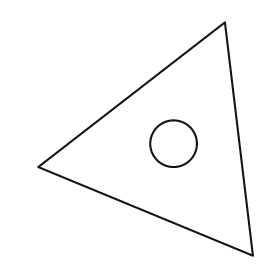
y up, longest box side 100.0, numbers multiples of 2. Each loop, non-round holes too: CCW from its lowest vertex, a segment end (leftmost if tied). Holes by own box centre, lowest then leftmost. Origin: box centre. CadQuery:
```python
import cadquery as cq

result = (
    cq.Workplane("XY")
    .moveTo(46.0, -50.0)
    .lineTo(34.0, 50.0)
    .lineTo(-46.0, -12.0)
    .close()
    .moveTo(12.0, -2.0)
    .circle(10.0)
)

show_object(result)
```